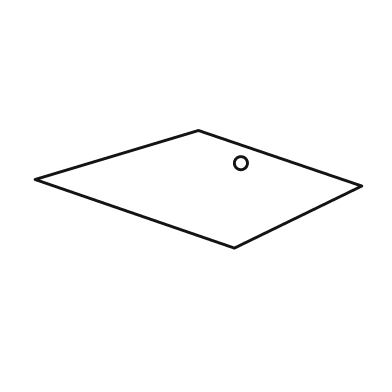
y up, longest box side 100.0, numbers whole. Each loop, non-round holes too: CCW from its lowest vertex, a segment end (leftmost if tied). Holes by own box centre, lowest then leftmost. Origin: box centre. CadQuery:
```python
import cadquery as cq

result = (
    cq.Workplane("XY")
    .moveTo(11.0, -18.0)
    .lineTo(50.0, 1.0)
    .lineTo(0.0, 18.0)
    .lineTo(-50.0, 3.0)
    .close()
    .moveTo(13.0, 8.0)
    .circle(2.0)
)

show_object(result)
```